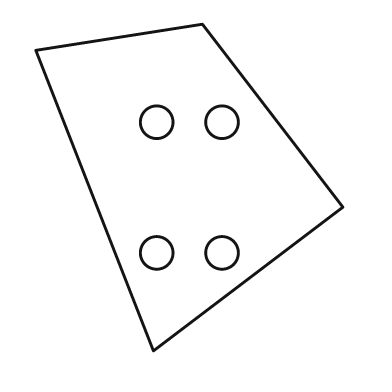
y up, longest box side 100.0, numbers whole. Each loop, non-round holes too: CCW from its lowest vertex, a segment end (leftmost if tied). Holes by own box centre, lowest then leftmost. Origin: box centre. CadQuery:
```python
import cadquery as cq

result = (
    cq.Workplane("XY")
    .moveTo(-11.0, -50.0)
    .lineTo(47.0, -6.0)
    .lineTo(4.0, 50.0)
    .lineTo(-47.0, 42.0)
    .close()
    .moveTo(-10.0, -20.0)
    .circle(5.0)
    .moveTo(10.0, -20.0)
    .circle(5.0)
    .moveTo(-10.0, 20.0)
    .circle(5.0)
    .moveTo(10.0, 20.0)
    .circle(5.0)
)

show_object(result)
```